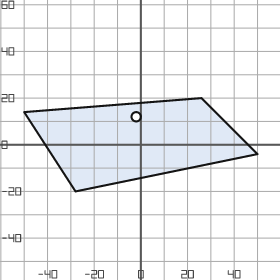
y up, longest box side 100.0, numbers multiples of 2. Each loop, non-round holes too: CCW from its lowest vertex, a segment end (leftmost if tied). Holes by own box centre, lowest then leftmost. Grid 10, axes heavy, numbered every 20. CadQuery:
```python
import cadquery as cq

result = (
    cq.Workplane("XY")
    .moveTo(-28.0, -20.0)
    .lineTo(50.0, -4.0)
    .lineTo(26.0, 20.0)
    .lineTo(-50.0, 14.0)
    .close()
    .moveTo(-2.0, 12.0)
    .circle(2.0)
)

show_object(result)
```